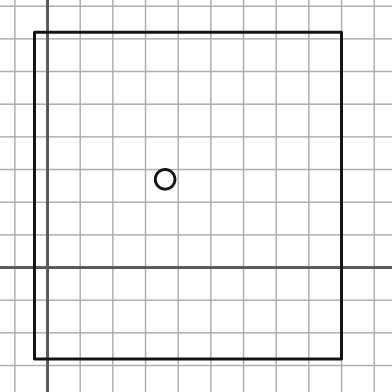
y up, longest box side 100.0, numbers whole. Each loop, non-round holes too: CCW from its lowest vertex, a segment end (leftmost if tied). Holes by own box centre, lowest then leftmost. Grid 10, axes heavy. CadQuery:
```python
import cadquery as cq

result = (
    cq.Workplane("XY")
    .moveTo(-4.0, -28.0)
    .lineTo(90.0, -28.0)
    .lineTo(90.0, 72.0)
    .lineTo(-4.0, 72.0)
    .close()
    .moveTo(36.0, 27.0)
    .circle(3.0)
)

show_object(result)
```